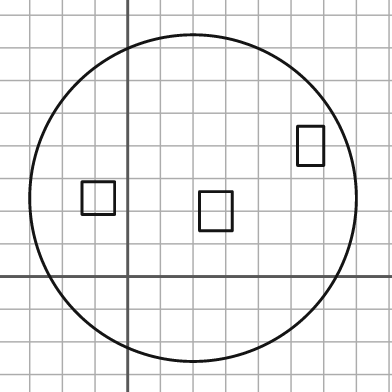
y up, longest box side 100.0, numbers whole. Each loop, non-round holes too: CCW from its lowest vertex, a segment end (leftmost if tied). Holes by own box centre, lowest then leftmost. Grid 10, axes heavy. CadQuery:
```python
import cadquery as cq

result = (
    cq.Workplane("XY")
    .moveTo(20.0, 24.0)
    .circle(50.0)
    .moveTo(22.0, 14.0)
    .lineTo(32.0, 14.0)
    .lineTo(32.0, 26.0)
    .lineTo(22.0, 26.0)
    .close()
    .moveTo(-14.0, 19.0)
    .lineTo(-4.0, 19.0)
    .lineTo(-4.0, 29.0)
    .lineTo(-14.0, 29.0)
    .close()
    .moveTo(52.0, 34.0)
    .lineTo(60.0, 34.0)
    .lineTo(60.0, 46.0)
    .lineTo(52.0, 46.0)
    .close()
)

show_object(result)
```